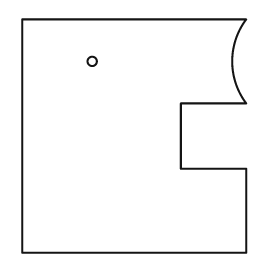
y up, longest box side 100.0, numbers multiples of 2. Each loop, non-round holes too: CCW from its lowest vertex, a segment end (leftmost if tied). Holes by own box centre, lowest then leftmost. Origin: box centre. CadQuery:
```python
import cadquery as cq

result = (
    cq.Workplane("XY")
    .moveTo(-48.0, -50.0)
    .lineTo(48.0, -50.0)
    .lineTo(48.0, -14.0)
    .lineTo(20.0, -14.0)
    .lineTo(20.0, 14.0)
    .lineTo(48.0, 14.0)
    .threePointArc((42.0, 32.0), (48.0, 50.0))
    .lineTo(-48.0, 50.0)
    .close()
    .moveTo(-18.0, 32.0)
    .circle(2.0)
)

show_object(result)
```